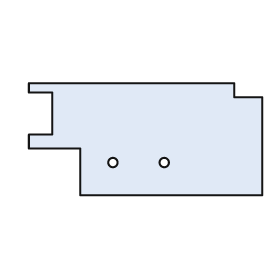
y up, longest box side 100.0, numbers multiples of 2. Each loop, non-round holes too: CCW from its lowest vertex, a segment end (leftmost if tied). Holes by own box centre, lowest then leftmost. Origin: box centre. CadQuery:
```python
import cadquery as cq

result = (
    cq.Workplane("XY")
    .moveTo(-28.0, -24.0)
    .lineTo(50.0, -24.0)
    .lineTo(50.0, 18.0)
    .lineTo(38.0, 18.0)
    .lineTo(38.0, 24.0)
    .lineTo(-50.0, 24.0)
    .lineTo(-50.0, 20.0)
    .lineTo(-40.0, 20.0)
    .lineTo(-40.0, 2.0)
    .lineTo(-50.0, 2.0)
    .lineTo(-50.0, -4.0)
    .lineTo(-28.0, -4.0)
    .close()
    .moveTo(-14.0, -10.0)
    .circle(2.0)
    .moveTo(8.0, -10.0)
    .circle(2.0)
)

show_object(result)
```